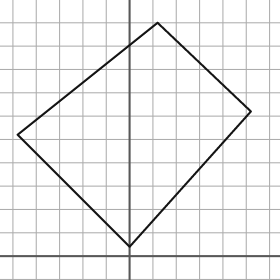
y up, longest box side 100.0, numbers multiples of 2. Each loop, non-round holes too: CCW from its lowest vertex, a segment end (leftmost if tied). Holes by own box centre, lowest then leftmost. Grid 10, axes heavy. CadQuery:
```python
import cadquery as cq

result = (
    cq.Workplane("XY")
    .moveTo(0.0, 4.0)
    .lineTo(52.0, 62.0)
    .lineTo(12.0, 100.0)
    .lineTo(-48.0, 52.0)
    .close()
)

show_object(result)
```